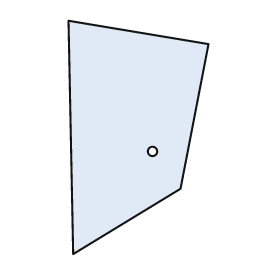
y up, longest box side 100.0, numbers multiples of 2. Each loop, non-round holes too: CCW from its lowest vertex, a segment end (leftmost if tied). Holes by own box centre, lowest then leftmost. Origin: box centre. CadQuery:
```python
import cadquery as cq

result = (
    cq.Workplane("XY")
    .moveTo(-28.0, -50.0)
    .lineTo(18.0, -22.0)
    .lineTo(30.0, 40.0)
    .lineTo(-30.0, 50.0)
    .close()
    .moveTo(6.0, -6.0)
    .circle(2.0)
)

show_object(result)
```